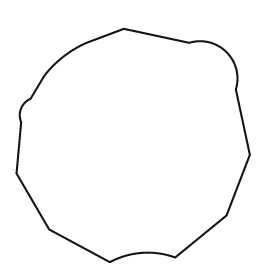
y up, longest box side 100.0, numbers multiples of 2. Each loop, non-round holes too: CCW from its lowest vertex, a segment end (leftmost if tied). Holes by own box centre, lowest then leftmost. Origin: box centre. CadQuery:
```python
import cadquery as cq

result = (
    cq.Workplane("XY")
    .moveTo(-10.0, -50.0)
    .threePointArc((4.0, -46.0), (18.0, -48.0))
    .lineTo(40.0, -30.0)
    .lineTo(50.0, -4.0)
    .lineTo(44.0, 24.0)
    .threePointArc((40.0, 40.0), (24.0, 44.0))
    .lineTo(-4.0, 50.0)
    .lineTo(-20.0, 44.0)
    .threePointArc((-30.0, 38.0), (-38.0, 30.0))
    .lineTo(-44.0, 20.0)
    .threePointArc((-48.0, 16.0), (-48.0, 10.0))
    .lineTo(-50.0, -12.0)
    .lineTo(-36.0, -36.0)
    .close()
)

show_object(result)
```